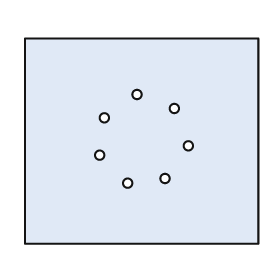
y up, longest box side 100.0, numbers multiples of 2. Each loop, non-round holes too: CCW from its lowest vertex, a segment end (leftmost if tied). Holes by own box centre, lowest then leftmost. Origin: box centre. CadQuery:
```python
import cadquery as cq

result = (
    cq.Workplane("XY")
    .moveTo(-50.0, -44.0)
    .lineTo(50.0, -44.0)
    .lineTo(50.0, 44.0)
    .lineTo(-50.0, 44.0)
    .close()
    .moveTo(-6.0, -18.0)
    .circle(2.0)
    .moveTo(10.0, -16.0)
    .circle(2.0)
    .moveTo(-18.0, -6.0)
    .circle(2.0)
    .moveTo(20.0, -2.0)
    .circle(2.0)
    .moveTo(-16.0, 10.0)
    .circle(2.0)
    .moveTo(14.0, 14.0)
    .circle(2.0)
    .moveTo(-2.0, 20.0)
    .circle(2.0)
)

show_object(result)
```